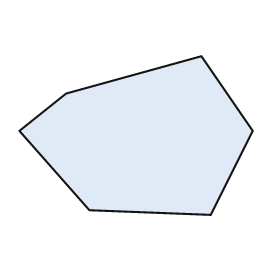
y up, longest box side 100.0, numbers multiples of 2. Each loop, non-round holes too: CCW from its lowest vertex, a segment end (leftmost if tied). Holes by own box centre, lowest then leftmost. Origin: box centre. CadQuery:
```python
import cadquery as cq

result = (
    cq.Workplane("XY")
    .moveTo(32.0, -34.0)
    .lineTo(50.0, 2.0)
    .lineTo(28.0, 34.0)
    .lineTo(-30.0, 18.0)
    .lineTo(-50.0, 2.0)
    .lineTo(-20.0, -32.0)
    .close()
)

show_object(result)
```